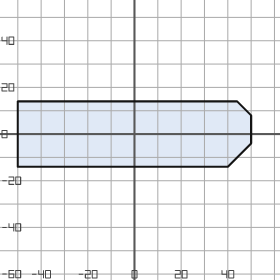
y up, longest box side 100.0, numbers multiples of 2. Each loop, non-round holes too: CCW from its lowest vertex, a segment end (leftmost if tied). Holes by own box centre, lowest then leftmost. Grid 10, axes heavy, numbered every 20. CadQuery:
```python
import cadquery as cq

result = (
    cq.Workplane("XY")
    .moveTo(-50.0, -14.0)
    .lineTo(40.0, -14.0)
    .lineTo(50.0, -4.0)
    .lineTo(50.0, 8.0)
    .lineTo(44.0, 14.0)
    .lineTo(-50.0, 14.0)
    .close()
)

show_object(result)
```